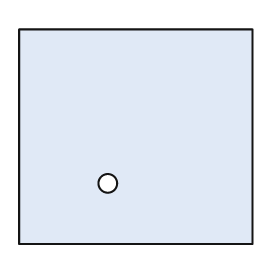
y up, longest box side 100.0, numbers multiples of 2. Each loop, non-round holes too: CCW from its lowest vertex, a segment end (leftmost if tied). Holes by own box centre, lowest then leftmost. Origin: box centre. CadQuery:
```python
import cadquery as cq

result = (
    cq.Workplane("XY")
    .moveTo(-50.0, -46.0)
    .lineTo(50.0, -46.0)
    .lineTo(50.0, 46.0)
    .lineTo(-50.0, 46.0)
    .close()
    .moveTo(-12.0, -20.0)
    .circle(4.0)
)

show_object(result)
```